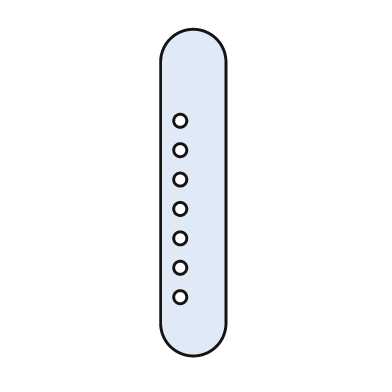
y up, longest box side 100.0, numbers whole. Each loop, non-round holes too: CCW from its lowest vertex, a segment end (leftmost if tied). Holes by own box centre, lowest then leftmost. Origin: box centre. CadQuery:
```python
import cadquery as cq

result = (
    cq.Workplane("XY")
    .moveTo(-10.0, -40.0)
    .threePointArc((0.0, -50.0), (10.0, -40.0))
    .lineTo(10.0, 40.0)
    .threePointArc((0.0, 50.0), (-10.0, 40.0))
    .close()
    .moveTo(-4.0, -32.0)
    .circle(2.0)
    .moveTo(-4.0, -23.0)
    .circle(2.0)
    .moveTo(-4.0, -14.0)
    .circle(2.0)
    .moveTo(-4.0, -5.0)
    .circle(2.0)
    .moveTo(-4.0, 4.0)
    .circle(2.0)
    .moveTo(-4.0, 13.0)
    .circle(2.0)
    .moveTo(-4.0, 22.0)
    .circle(2.0)
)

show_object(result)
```